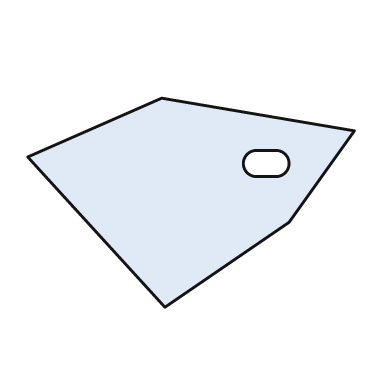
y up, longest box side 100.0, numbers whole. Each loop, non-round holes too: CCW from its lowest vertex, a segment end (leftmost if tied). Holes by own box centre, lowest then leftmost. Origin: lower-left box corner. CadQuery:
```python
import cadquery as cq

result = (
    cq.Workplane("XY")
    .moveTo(42.0, 0.0)
    .lineTo(80.0, 26.0)
    .lineTo(100.0, 54.0)
    .lineTo(41.0, 64.0)
    .lineTo(0.0, 46.0)
    .close()
    .moveTo(70.0, 40.0)
    .lineTo(76.0, 40.0)
    .threePointArc((80.0, 44.0), (76.0, 48.0))
    .lineTo(70.0, 48.0)
    .threePointArc((66.0, 44.0), (70.0, 40.0))
    .close()
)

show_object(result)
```